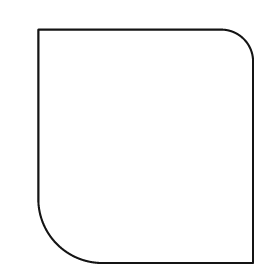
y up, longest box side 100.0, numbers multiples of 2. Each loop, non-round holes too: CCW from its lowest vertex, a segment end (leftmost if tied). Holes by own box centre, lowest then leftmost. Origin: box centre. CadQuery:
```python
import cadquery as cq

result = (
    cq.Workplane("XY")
    .moveTo(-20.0, -50.0)
    .lineTo(46.0, -50.0)
    .lineTo(46.0, 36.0)
    .threePointArc((42.0, 46.0), (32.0, 50.0))
    .lineTo(-46.0, 50.0)
    .lineTo(-46.0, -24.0)
    .threePointArc((-38.0, -42.0), (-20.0, -50.0))
    .close()
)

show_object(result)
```